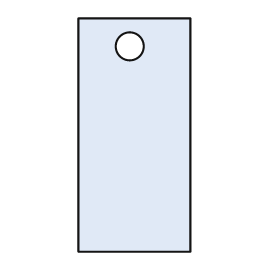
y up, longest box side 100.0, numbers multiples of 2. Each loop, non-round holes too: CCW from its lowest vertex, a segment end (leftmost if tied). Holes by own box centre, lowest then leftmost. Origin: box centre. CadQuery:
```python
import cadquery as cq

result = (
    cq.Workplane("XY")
    .moveTo(-24.0, -50.0)
    .lineTo(24.0, -50.0)
    .lineTo(24.0, 50.0)
    .lineTo(-24.0, 50.0)
    .close()
    .moveTo(-2.0, 38.0)
    .circle(6.0)
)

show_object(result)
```